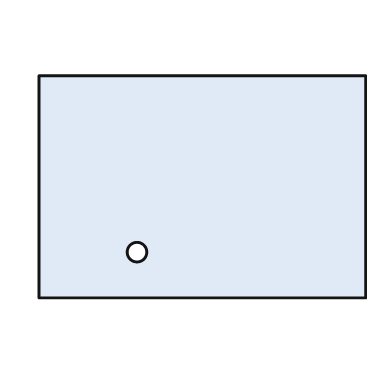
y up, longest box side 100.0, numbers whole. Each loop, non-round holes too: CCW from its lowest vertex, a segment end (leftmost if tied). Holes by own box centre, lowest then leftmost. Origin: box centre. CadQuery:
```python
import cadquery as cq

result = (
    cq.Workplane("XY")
    .moveTo(-50.0, -34.0)
    .lineTo(50.0, -34.0)
    .lineTo(50.0, 34.0)
    .lineTo(-50.0, 34.0)
    .close()
    .moveTo(-20.0, -20.0)
    .circle(3.0)
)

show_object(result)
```